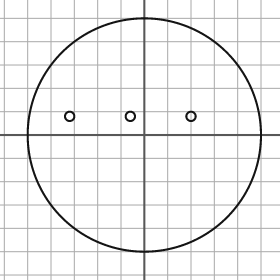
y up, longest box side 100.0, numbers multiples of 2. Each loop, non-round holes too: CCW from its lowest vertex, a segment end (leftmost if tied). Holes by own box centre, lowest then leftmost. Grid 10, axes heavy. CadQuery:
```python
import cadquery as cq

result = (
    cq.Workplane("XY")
    .moveTo(0.0, 0.0)
    .circle(50.0)
    .moveTo(-32.0, 8.0)
    .circle(2.0)
    .moveTo(-6.0, 8.0)
    .circle(2.0)
    .moveTo(20.0, 8.0)
    .circle(2.0)
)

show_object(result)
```